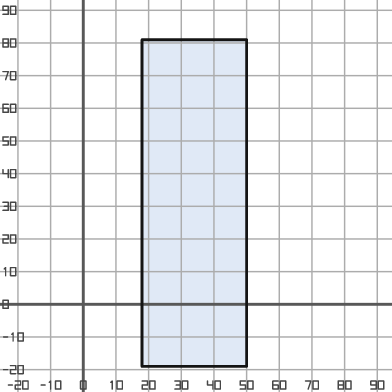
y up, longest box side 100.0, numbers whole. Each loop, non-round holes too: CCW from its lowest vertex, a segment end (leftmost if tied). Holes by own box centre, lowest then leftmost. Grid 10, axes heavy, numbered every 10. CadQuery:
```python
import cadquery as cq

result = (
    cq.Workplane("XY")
    .moveTo(18.0, -19.0)
    .lineTo(50.0, -19.0)
    .lineTo(50.0, 81.0)
    .lineTo(18.0, 81.0)
    .close()
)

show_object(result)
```